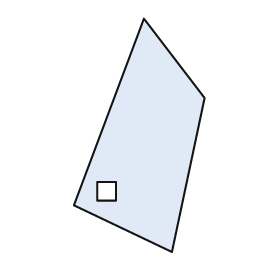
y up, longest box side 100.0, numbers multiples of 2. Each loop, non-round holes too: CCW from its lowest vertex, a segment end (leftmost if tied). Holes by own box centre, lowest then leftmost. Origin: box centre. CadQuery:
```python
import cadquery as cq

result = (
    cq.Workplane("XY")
    .moveTo(14.0, -50.0)
    .lineTo(28.0, 16.0)
    .lineTo(2.0, 50.0)
    .lineTo(-28.0, -30.0)
    .close()
    .moveTo(-18.0, -28.0)
    .lineTo(-10.0, -28.0)
    .lineTo(-10.0, -20.0)
    .lineTo(-18.0, -20.0)
    .close()
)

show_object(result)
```